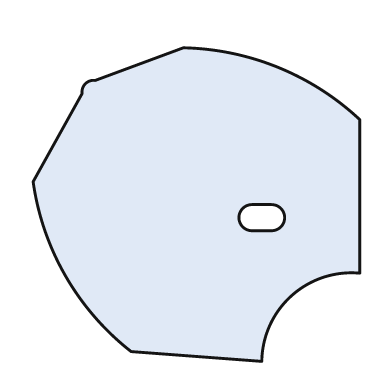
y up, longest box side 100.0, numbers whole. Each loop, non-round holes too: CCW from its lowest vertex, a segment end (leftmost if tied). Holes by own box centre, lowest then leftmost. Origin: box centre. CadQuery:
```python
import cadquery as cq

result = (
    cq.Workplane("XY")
    .moveTo(20.0, -48.0)
    .threePointArc((29.0, -28.0), (50.0, -21.0))
    .lineTo(50.0, 26.0)
    .threePointArc((25.0, 42.0), (-4.0, 48.0))
    .lineTo(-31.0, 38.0)
    .threePointArc((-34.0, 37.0), (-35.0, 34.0))
    .lineTo(-50.0, 7.0)
    .threePointArc((-40.0, -22.0), (-20.0, -45.0))
    .close()
    .moveTo(17.0, -8.0)
    .lineTo(23.0, -8.0)
    .threePointArc((27.0, -4.0), (23.0, 0.0))
    .lineTo(17.0, 0.0)
    .threePointArc((13.0, -4.0), (17.0, -8.0))
    .close()
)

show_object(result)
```